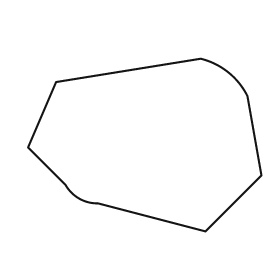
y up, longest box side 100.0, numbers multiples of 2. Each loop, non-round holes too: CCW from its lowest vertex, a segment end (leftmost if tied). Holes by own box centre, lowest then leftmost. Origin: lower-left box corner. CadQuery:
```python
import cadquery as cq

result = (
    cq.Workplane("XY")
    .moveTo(76.0, 0.0)
    .lineTo(100.0, 24.0)
    .lineTo(94.0, 58.0)
    .threePointArc((86.0, 68.0), (74.0, 74.0))
    .lineTo(12.0, 64.0)
    .lineTo(0.0, 36.0)
    .lineTo(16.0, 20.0)
    .threePointArc((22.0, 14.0), (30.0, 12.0))
    .close()
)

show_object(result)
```